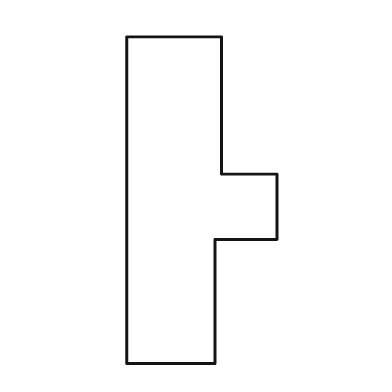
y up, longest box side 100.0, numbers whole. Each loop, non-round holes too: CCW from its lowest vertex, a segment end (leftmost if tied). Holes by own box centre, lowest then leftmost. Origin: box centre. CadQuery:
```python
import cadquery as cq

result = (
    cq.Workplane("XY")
    .moveTo(-23.0, -50.0)
    .lineTo(4.0, -50.0)
    .lineTo(4.0, -12.0)
    .lineTo(23.0, -12.0)
    .lineTo(23.0, 8.0)
    .lineTo(6.0, 8.0)
    .lineTo(6.0, 50.0)
    .lineTo(-23.0, 50.0)
    .close()
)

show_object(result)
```